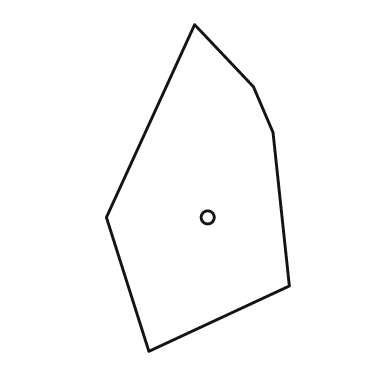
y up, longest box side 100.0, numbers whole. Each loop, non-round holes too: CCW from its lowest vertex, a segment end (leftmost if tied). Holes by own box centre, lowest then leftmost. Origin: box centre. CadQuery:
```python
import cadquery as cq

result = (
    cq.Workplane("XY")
    .moveTo(-15.0, -50.0)
    .lineTo(28.0, -30.0)
    .lineTo(23.0, 17.0)
    .lineTo(17.0, 31.0)
    .lineTo(-1.0, 50.0)
    .lineTo(-28.0, -9.0)
    .close()
    .moveTo(3.0, -9.0)
    .circle(2.0)
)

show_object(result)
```